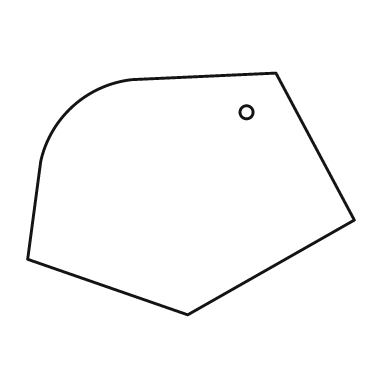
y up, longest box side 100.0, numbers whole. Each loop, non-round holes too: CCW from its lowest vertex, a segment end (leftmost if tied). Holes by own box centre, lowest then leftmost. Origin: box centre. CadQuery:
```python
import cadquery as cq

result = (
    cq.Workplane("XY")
    .moveTo(-1.0, -37.0)
    .lineTo(50.0, -8.0)
    .lineTo(26.0, 37.0)
    .lineTo(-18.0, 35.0)
    .threePointArc((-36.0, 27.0), (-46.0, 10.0))
    .lineTo(-50.0, -20.0)
    .close()
    .moveTo(17.0, 25.0)
    .circle(2.0)
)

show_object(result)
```